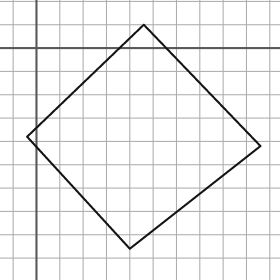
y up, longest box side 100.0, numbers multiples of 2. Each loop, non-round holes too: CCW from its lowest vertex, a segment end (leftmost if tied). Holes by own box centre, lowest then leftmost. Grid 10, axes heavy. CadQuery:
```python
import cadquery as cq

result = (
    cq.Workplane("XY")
    .moveTo(40.0, -86.0)
    .lineTo(96.0, -42.0)
    .lineTo(46.0, 10.0)
    .lineTo(-4.0, -38.0)
    .close()
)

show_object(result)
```